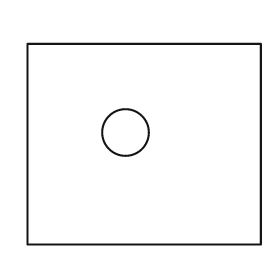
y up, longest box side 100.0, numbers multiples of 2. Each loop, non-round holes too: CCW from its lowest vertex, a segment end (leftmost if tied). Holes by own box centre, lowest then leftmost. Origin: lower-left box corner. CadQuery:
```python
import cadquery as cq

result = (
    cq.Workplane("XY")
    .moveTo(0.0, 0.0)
    .lineTo(100.0, 0.0)
    .lineTo(100.0, 86.0)
    .lineTo(0.0, 86.0)
    .close()
    .moveTo(42.0, 48.0)
    .circle(10.0)
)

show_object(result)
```